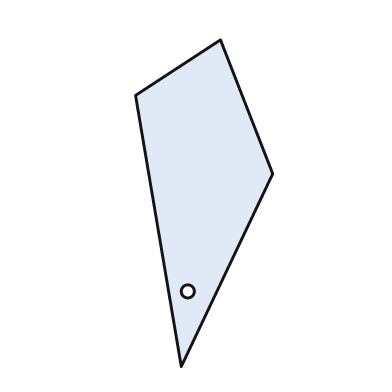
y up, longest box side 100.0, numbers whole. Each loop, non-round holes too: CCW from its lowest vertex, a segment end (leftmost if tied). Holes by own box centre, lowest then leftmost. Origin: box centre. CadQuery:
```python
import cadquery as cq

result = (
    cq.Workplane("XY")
    .moveTo(-7.0, -50.0)
    .lineTo(21.0, 9.0)
    .lineTo(5.0, 50.0)
    .lineTo(-21.0, 33.0)
    .close()
    .moveTo(-5.0, -27.0)
    .circle(2.0)
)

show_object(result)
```